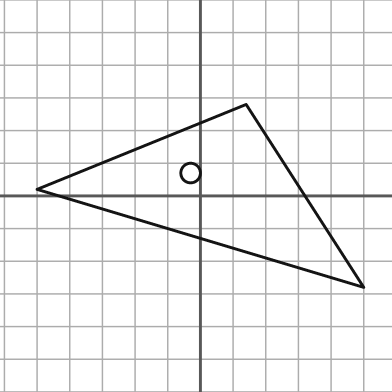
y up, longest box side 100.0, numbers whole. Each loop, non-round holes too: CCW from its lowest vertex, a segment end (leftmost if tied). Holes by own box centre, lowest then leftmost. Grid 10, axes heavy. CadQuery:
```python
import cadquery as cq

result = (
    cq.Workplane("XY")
    .moveTo(50.0, -28.0)
    .lineTo(14.0, 28.0)
    .lineTo(-50.0, 2.0)
    .close()
    .moveTo(-3.0, 7.0)
    .circle(3.0)
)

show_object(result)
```